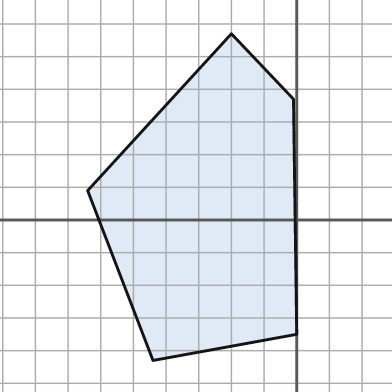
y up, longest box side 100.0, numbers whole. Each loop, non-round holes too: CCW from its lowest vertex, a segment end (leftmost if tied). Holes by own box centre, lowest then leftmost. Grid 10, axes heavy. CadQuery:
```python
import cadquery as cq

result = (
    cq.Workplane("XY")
    .moveTo(-44.0, -43.0)
    .lineTo(0.0, -35.0)
    .lineTo(-1.0, 37.0)
    .lineTo(-20.0, 57.0)
    .lineTo(-64.0, 9.0)
    .close()
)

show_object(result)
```